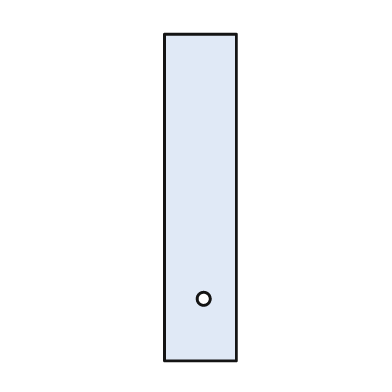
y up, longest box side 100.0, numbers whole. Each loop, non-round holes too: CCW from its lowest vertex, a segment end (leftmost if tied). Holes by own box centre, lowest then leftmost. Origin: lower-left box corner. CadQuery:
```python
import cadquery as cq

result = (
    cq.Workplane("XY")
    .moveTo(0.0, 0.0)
    .lineTo(22.0, 0.0)
    .lineTo(22.0, 100.0)
    .lineTo(0.0, 100.0)
    .close()
    .moveTo(12.0, 19.0)
    .circle(2.0)
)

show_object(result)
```